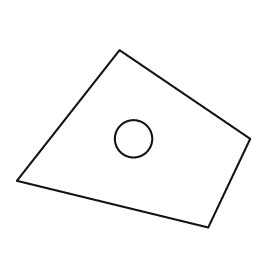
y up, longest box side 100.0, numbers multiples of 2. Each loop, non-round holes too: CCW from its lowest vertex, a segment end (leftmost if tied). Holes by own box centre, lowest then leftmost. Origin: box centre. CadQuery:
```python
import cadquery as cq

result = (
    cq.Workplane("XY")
    .moveTo(32.0, -38.0)
    .lineTo(50.0, 0.0)
    .lineTo(-6.0, 38.0)
    .lineTo(-50.0, -18.0)
    .close()
    .moveTo(0.0, 0.0)
    .circle(8.0)
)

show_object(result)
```